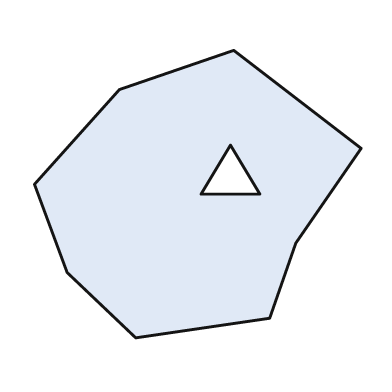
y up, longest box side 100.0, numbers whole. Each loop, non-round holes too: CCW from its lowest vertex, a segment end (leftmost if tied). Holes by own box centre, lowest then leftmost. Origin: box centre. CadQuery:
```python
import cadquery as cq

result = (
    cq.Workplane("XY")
    .moveTo(-19.0, -44.0)
    .lineTo(22.0, -38.0)
    .lineTo(30.0, -15.0)
    .lineTo(50.0, 14.0)
    .lineTo(11.0, 44.0)
    .lineTo(-24.0, 32.0)
    .lineTo(-50.0, 3.0)
    .lineTo(-40.0, -24.0)
    .close()
    .moveTo(1.0, 0.0)
    .lineTo(19.0, 0.0)
    .lineTo(10.0, 15.0)
    .close()
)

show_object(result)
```